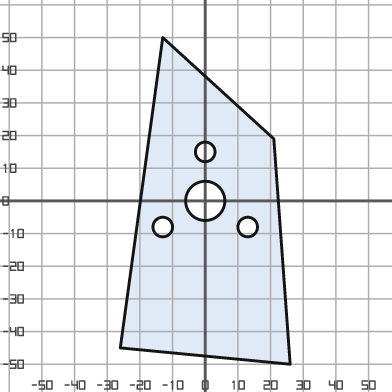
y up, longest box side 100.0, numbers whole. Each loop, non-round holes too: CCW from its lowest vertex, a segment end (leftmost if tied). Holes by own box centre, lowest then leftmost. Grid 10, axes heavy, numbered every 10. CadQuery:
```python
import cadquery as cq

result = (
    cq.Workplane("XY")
    .moveTo(26.0, -50.0)
    .lineTo(21.0, 19.0)
    .lineTo(-13.0, 50.0)
    .lineTo(-26.0, -45.0)
    .close()
    .moveTo(-13.0, -8.0)
    .circle(3.0)
    .moveTo(13.0, -8.0)
    .circle(3.0)
    .moveTo(0.0, 0.0)
    .circle(6.0)
    .moveTo(0.0, 15.0)
    .circle(3.0)
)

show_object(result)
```